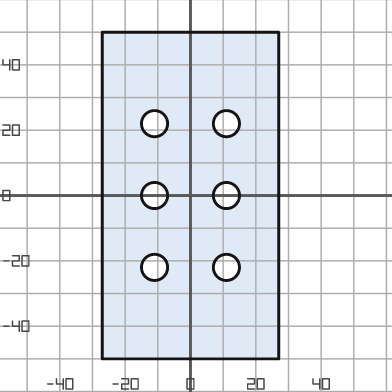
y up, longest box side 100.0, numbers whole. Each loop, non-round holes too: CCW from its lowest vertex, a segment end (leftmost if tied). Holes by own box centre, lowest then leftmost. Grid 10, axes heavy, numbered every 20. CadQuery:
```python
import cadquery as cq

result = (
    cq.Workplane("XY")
    .moveTo(-27.0, -50.0)
    .lineTo(27.0, -50.0)
    .lineTo(27.0, 50.0)
    .lineTo(-27.0, 50.0)
    .close()
    .moveTo(-11.0, -22.0)
    .circle(4.0)
    .moveTo(11.0, -22.0)
    .circle(4.0)
    .moveTo(-11.0, 0.0)
    .circle(4.0)
    .moveTo(11.0, 0.0)
    .circle(4.0)
    .moveTo(-11.0, 22.0)
    .circle(4.0)
    .moveTo(11.0, 22.0)
    .circle(4.0)
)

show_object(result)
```